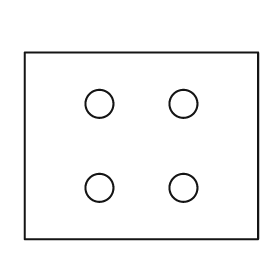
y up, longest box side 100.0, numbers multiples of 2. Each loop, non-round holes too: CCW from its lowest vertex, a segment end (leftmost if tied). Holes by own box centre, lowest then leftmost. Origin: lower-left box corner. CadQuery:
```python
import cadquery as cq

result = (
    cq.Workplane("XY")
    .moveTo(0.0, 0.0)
    .lineTo(100.0, 0.0)
    .lineTo(100.0, 80.0)
    .lineTo(0.0, 80.0)
    .close()
    .moveTo(32.0, 22.0)
    .circle(6.0)
    .moveTo(68.0, 22.0)
    .circle(6.0)
    .moveTo(32.0, 58.0)
    .circle(6.0)
    .moveTo(68.0, 58.0)
    .circle(6.0)
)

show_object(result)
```